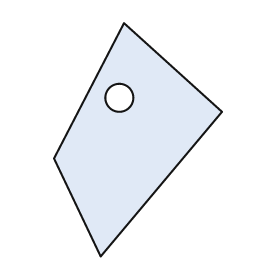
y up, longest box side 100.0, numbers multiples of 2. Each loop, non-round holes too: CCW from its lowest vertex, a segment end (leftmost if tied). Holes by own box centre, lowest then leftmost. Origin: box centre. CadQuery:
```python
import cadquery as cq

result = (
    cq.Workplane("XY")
    .moveTo(-16.0, -50.0)
    .lineTo(36.0, 12.0)
    .lineTo(-6.0, 50.0)
    .lineTo(-36.0, -8.0)
    .close()
    .moveTo(-8.0, 18.0)
    .circle(6.0)
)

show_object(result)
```